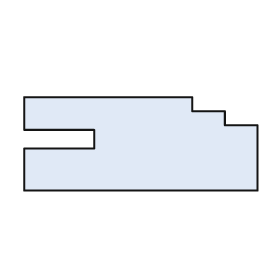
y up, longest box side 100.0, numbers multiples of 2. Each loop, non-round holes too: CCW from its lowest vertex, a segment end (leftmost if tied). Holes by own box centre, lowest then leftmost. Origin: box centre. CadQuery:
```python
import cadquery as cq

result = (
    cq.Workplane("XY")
    .moveTo(-50.0, -20.0)
    .lineTo(50.0, -20.0)
    .lineTo(50.0, 8.0)
    .lineTo(36.0, 8.0)
    .lineTo(36.0, 14.0)
    .lineTo(22.0, 14.0)
    .lineTo(22.0, 20.0)
    .lineTo(-50.0, 20.0)
    .lineTo(-50.0, 6.0)
    .lineTo(-20.0, 6.0)
    .lineTo(-20.0, -2.0)
    .lineTo(-50.0, -2.0)
    .close()
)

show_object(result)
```